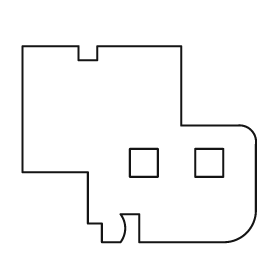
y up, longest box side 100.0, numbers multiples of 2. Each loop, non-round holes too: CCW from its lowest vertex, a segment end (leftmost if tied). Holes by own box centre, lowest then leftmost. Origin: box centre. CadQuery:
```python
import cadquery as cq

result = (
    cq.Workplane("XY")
    .moveTo(-16.0, -42.0)
    .lineTo(-8.0, -42.0)
    .threePointArc((-6.0, -36.0), (-8.0, -30.0))
    .lineTo(0.0, -30.0)
    .lineTo(0.0, -42.0)
    .lineTo(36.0, -42.0)
    .threePointArc((46.0, -38.0), (50.0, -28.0))
    .lineTo(50.0, 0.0)
    .threePointArc((48.0, 6.0), (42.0, 8.0))
    .lineTo(18.0, 8.0)
    .lineTo(18.0, 42.0)
    .lineTo(-18.0, 42.0)
    .lineTo(-18.0, 36.0)
    .lineTo(-26.0, 36.0)
    .lineTo(-26.0, 42.0)
    .lineTo(-50.0, 42.0)
    .lineTo(-50.0, -12.0)
    .lineTo(-22.0, -12.0)
    .lineTo(-22.0, -34.0)
    .lineTo(-16.0, -34.0)
    .close()
    .moveTo(-4.0, -14.0)
    .lineTo(8.0, -14.0)
    .lineTo(8.0, -2.0)
    .lineTo(-4.0, -2.0)
    .close()
    .moveTo(24.0, -14.0)
    .lineTo(36.0, -14.0)
    .lineTo(36.0, -2.0)
    .lineTo(24.0, -2.0)
    .close()
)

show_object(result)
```